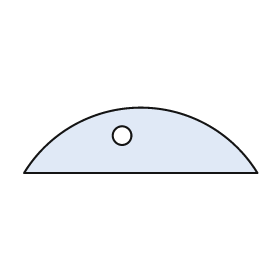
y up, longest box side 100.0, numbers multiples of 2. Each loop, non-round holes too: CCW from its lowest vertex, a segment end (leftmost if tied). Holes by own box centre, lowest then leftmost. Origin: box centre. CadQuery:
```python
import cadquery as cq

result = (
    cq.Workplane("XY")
    .moveTo(-50.0, -14.0)
    .lineTo(50.0, -14.0)
    .threePointArc((0.0, 14.0), (-50.0, -14.0))
    .close()
    .moveTo(-8.0, 2.0)
    .circle(4.0)
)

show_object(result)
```